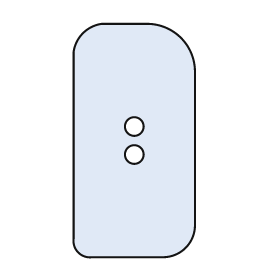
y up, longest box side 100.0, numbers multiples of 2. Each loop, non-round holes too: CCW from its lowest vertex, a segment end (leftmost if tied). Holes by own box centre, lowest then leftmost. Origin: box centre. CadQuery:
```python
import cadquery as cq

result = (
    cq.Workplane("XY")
    .moveTo(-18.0, -50.0)
    .lineTo(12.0, -50.0)
    .threePointArc((22.0, -46.0), (26.0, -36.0))
    .lineTo(26.0, 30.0)
    .threePointArc((20.0, 44.0), (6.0, 50.0))
    .lineTo(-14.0, 50.0)
    .threePointArc((-22.0, 46.0), (-26.0, 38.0))
    .lineTo(-26.0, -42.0)
    .threePointArc((-24.0, -48.0), (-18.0, -50.0))
    .close()
    .moveTo(0.0, -6.0)
    .circle(4.0)
    .moveTo(0.0, 6.0)
    .circle(4.0)
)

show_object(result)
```